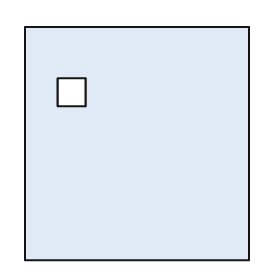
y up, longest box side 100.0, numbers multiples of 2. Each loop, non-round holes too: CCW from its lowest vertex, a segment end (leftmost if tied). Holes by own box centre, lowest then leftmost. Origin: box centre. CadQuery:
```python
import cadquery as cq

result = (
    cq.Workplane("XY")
    .moveTo(-48.0, -50.0)
    .lineTo(48.0, -50.0)
    .lineTo(48.0, 50.0)
    .lineTo(-48.0, 50.0)
    .close()
    .moveTo(-34.0, 16.0)
    .lineTo(-22.0, 16.0)
    .lineTo(-22.0, 28.0)
    .lineTo(-34.0, 28.0)
    .close()
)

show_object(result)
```